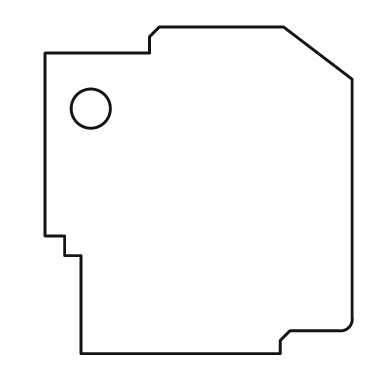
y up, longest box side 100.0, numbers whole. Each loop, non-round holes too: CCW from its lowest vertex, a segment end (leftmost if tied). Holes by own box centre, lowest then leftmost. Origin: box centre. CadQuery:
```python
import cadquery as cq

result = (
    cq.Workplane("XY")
    .moveTo(-36.0, -50.0)
    .lineTo(25.0, -50.0)
    .lineTo(25.0, -46.0)
    .lineTo(28.0, -43.0)
    .lineTo(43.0, -43.0)
    .threePointArc((46.0, -42.0), (47.0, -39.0))
    .lineTo(47.0, 34.0)
    .lineTo(26.0, 50.0)
    .lineTo(-12.0, 50.0)
    .lineTo(-15.0, 47.0)
    .lineTo(-15.0, 42.0)
    .lineTo(-47.0, 42.0)
    .lineTo(-47.0, -14.0)
    .lineTo(-41.0, -14.0)
    .lineTo(-41.0, -20.0)
    .lineTo(-36.0, -20.0)
    .close()
    .moveTo(-33.0, 25.0)
    .circle(6.0)
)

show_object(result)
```